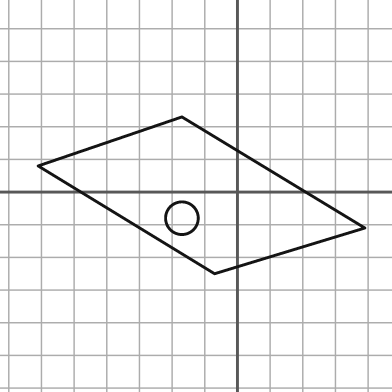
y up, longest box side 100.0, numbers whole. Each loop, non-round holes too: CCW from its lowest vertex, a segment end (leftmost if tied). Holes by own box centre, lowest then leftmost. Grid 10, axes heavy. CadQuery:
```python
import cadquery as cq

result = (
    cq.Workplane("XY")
    .moveTo(-7.0, -25.0)
    .lineTo(39.0, -11.0)
    .lineTo(-17.0, 23.0)
    .lineTo(-61.0, 8.0)
    .close()
    .moveTo(-17.0, -8.0)
    .circle(5.0)
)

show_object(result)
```